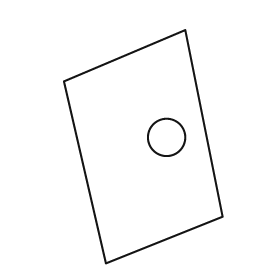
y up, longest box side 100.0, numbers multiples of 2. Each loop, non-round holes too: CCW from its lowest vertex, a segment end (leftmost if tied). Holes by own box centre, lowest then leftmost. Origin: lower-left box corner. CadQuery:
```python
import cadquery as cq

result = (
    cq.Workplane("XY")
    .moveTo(18.0, 0.0)
    .lineTo(68.0, 20.0)
    .lineTo(52.0, 100.0)
    .lineTo(0.0, 78.0)
    .close()
    .moveTo(44.0, 54.0)
    .circle(8.0)
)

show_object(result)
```